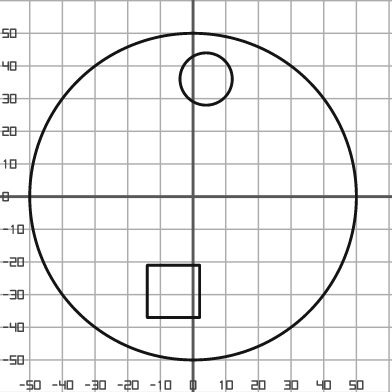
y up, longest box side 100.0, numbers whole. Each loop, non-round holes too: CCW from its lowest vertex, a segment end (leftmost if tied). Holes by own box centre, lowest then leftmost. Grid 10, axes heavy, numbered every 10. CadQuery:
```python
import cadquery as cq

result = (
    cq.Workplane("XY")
    .moveTo(0.0, 0.0)
    .circle(50.0)
    .moveTo(-14.0, -37.0)
    .lineTo(2.0, -37.0)
    .lineTo(2.0, -21.0)
    .lineTo(-14.0, -21.0)
    .close()
    .moveTo(4.0, 36.0)
    .circle(8.0)
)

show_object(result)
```